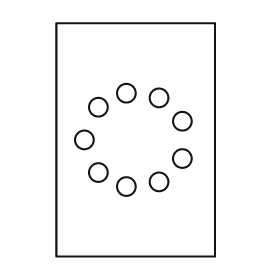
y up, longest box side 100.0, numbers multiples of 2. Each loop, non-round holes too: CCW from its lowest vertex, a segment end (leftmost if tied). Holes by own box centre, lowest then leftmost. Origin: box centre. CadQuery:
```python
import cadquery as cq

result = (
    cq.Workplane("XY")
    .moveTo(-34.0, -50.0)
    .lineTo(34.0, -50.0)
    .lineTo(34.0, 50.0)
    .lineTo(-34.0, 50.0)
    .close()
    .moveTo(-4.0, -20.0)
    .circle(4.0)
    .moveTo(10.0, -18.0)
    .circle(4.0)
    .moveTo(-16.0, -14.0)
    .circle(4.0)
    .moveTo(20.0, -8.0)
    .circle(4.0)
    .moveTo(-22.0, 0.0)
    .circle(4.0)
    .moveTo(20.0, 8.0)
    .circle(4.0)
    .moveTo(-16.0, 14.0)
    .circle(4.0)
    .moveTo(10.0, 18.0)
    .circle(4.0)
    .moveTo(-4.0, 20.0)
    .circle(4.0)
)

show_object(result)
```